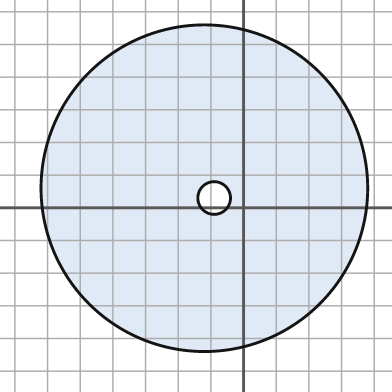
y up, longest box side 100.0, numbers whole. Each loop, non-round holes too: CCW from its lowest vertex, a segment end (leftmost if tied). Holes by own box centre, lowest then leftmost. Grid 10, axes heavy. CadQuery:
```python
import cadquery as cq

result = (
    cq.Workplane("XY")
    .moveTo(-12.0, 6.0)
    .circle(50.0)
    .moveTo(-9.0, 3.0)
    .circle(5.0)
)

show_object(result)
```